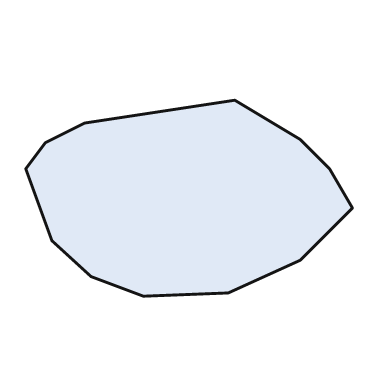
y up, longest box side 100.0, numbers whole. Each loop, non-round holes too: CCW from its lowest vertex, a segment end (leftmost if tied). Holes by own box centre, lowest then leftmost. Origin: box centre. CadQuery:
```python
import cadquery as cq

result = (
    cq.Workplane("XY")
    .moveTo(-14.0, -30.0)
    .lineTo(12.0, -29.0)
    .lineTo(34.0, -19.0)
    .lineTo(50.0, -3.0)
    .lineTo(43.0, 9.0)
    .lineTo(34.0, 18.0)
    .lineTo(14.0, 30.0)
    .lineTo(-32.0, 23.0)
    .lineTo(-44.0, 17.0)
    .lineTo(-50.0, 9.0)
    .lineTo(-42.0, -13.0)
    .lineTo(-30.0, -24.0)
    .close()
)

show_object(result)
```